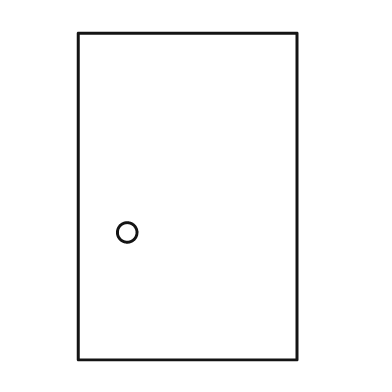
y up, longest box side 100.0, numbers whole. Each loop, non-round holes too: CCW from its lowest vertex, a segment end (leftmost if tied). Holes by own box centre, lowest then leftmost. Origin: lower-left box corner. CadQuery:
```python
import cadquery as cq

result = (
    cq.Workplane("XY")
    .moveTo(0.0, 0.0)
    .lineTo(67.0, 0.0)
    .lineTo(67.0, 100.0)
    .lineTo(0.0, 100.0)
    .close()
    .moveTo(15.0, 39.0)
    .circle(3.0)
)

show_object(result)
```